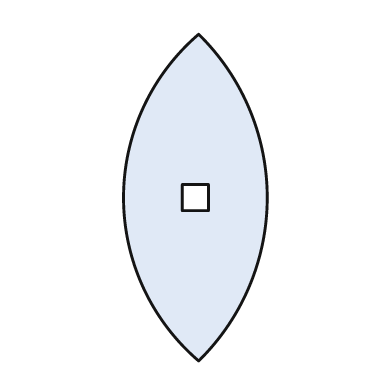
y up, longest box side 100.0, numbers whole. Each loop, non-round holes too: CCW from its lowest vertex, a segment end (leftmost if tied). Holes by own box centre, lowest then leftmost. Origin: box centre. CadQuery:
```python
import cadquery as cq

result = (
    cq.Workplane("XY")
    .moveTo(1.0, -50.0)
    .threePointArc((22.0, 0.0), (1.0, 50.0))
    .threePointArc((-22.0, 0.0), (1.0, -50.0))
    .close()
    .moveTo(-4.0, -4.0)
    .lineTo(4.0, -4.0)
    .lineTo(4.0, 4.0)
    .lineTo(-4.0, 4.0)
    .close()
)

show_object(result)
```